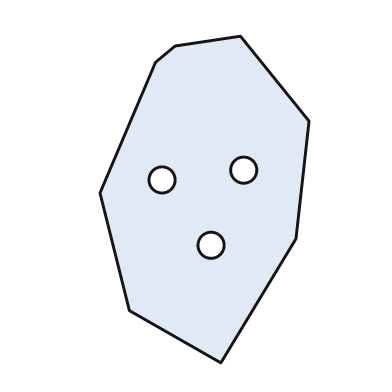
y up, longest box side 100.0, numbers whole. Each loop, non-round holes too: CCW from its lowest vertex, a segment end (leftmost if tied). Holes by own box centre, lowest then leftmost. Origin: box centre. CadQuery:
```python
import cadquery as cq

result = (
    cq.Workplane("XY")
    .moveTo(5.0, -50.0)
    .lineTo(28.0, -12.0)
    .lineTo(32.0, 24.0)
    .lineTo(11.0, 50.0)
    .lineTo(-9.0, 47.0)
    .lineTo(-15.0, 42.0)
    .lineTo(-32.0, 2.0)
    .lineTo(-23.0, -34.0)
    .close()
    .moveTo(2.0, -14.0)
    .circle(4.0)
    .moveTo(-13.0, 6.0)
    .circle(4.0)
    .moveTo(12.0, 9.0)
    .circle(4.0)
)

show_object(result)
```